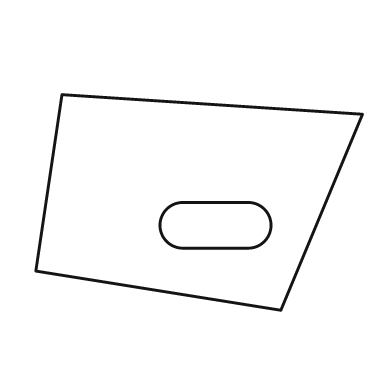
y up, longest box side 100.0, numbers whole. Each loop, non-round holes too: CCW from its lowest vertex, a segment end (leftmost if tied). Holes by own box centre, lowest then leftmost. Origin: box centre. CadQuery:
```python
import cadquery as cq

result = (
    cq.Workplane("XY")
    .moveTo(25.0, -33.0)
    .lineTo(50.0, 27.0)
    .lineTo(-42.0, 33.0)
    .lineTo(-50.0, -21.0)
    .close()
    .moveTo(-5.0, -14.0)
    .lineTo(15.0, -14.0)
    .threePointArc((22.0, -7.0), (15.0, 0.0))
    .lineTo(-5.0, 0.0)
    .threePointArc((-12.0, -7.0), (-5.0, -14.0))
    .close()
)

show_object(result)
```